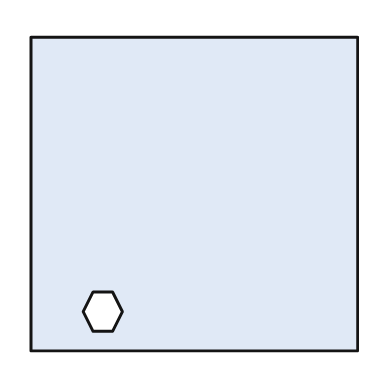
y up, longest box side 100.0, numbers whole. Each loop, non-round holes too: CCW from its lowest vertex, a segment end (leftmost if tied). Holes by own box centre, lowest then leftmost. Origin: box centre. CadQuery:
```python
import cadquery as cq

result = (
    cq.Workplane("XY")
    .moveTo(-50.0, -48.0)
    .lineTo(50.0, -48.0)
    .lineTo(50.0, 48.0)
    .lineTo(-50.0, 48.0)
    .close()
    .moveTo(-31.0, -42.0)
    .lineTo(-25.0, -42.0)
    .lineTo(-22.0, -36.0)
    .lineTo(-25.0, -30.0)
    .lineTo(-31.0, -30.0)
    .lineTo(-34.0, -36.0)
    .close()
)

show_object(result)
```